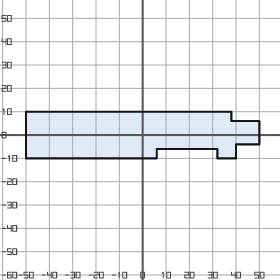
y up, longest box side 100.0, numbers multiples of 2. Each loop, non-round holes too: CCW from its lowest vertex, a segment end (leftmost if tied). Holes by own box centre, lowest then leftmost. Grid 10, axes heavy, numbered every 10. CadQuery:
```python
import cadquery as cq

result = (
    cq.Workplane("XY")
    .moveTo(-50.0, -10.0)
    .lineTo(6.0, -10.0)
    .lineTo(6.0, -6.0)
    .lineTo(32.0, -6.0)
    .lineTo(32.0, -10.0)
    .lineTo(40.0, -10.0)
    .lineTo(40.0, -4.0)
    .lineTo(50.0, -4.0)
    .lineTo(50.0, 6.0)
    .lineTo(38.0, 6.0)
    .lineTo(38.0, 10.0)
    .lineTo(-50.0, 10.0)
    .close()
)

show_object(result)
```